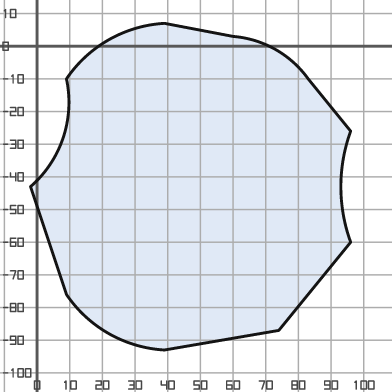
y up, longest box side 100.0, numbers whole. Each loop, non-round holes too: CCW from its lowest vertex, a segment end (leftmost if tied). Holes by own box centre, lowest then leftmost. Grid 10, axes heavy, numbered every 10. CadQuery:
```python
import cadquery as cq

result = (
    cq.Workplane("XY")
    .moveTo(39.0, -93.0)
    .lineTo(74.0, -87.0)
    .lineTo(96.0, -60.0)
    .threePointArc((93.0, -43.0), (96.0, -26.0))
    .lineTo(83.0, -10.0)
    .threePointArc((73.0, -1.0), (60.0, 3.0))
    .lineTo(39.0, 7.0)
    .threePointArc((22.0, 2.0), (9.0, -10.0))
    .threePointArc((8.0, -28.0), (-2.0, -43.0))
    .lineTo(9.0, -76.0)
    .threePointArc((22.0, -88.0), (39.0, -93.0))
    .close()
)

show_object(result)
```